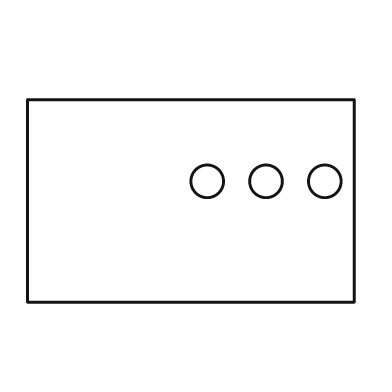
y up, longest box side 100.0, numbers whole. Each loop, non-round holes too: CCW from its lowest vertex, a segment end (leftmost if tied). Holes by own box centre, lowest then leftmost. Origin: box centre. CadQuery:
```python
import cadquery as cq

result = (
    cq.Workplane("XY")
    .moveTo(-50.0, -31.0)
    .lineTo(50.0, -31.0)
    .lineTo(50.0, 31.0)
    .lineTo(-50.0, 31.0)
    .close()
    .moveTo(5.0, 6.0)
    .circle(5.0)
    .moveTo(23.0, 6.0)
    .circle(5.0)
    .moveTo(41.0, 6.0)
    .circle(5.0)
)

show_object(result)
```